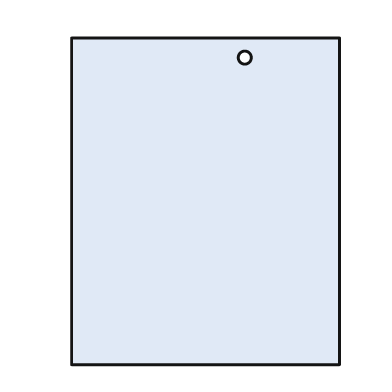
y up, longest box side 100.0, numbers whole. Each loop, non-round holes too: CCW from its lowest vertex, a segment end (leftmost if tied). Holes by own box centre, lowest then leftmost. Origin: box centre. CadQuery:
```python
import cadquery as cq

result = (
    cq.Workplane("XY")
    .moveTo(-41.0, -50.0)
    .lineTo(41.0, -50.0)
    .lineTo(41.0, 50.0)
    .lineTo(-41.0, 50.0)
    .close()
    .moveTo(12.0, 44.0)
    .circle(2.0)
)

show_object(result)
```